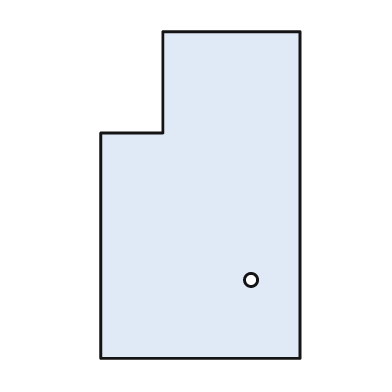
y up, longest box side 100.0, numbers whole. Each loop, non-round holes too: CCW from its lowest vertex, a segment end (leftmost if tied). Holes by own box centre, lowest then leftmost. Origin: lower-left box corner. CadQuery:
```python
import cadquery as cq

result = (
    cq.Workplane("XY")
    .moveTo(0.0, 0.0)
    .lineTo(61.0, 0.0)
    .lineTo(61.0, 100.0)
    .lineTo(19.0, 100.0)
    .lineTo(19.0, 69.0)
    .lineTo(0.0, 69.0)
    .close()
    .moveTo(46.0, 24.0)
    .circle(2.0)
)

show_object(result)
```